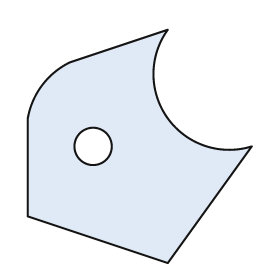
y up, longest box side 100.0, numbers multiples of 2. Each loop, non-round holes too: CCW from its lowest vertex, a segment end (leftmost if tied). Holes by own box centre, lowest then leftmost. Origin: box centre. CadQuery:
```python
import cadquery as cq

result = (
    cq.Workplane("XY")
    .moveTo(12.0, -50.0)
    .lineTo(48.0, 0.0)
    .threePointArc((12.0, 12.0), (12.0, 50.0))
    .lineTo(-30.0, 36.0)
    .threePointArc((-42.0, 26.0), (-48.0, 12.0))
    .lineTo(-48.0, -30.0)
    .close()
    .moveTo(-20.0, 0.0)
    .circle(8.0)
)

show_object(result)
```